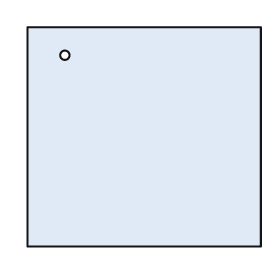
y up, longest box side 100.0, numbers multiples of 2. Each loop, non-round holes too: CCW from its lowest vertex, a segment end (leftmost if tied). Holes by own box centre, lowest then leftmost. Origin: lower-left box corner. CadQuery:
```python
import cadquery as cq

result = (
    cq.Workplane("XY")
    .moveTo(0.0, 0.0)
    .lineTo(100.0, 0.0)
    .lineTo(100.0, 94.0)
    .lineTo(0.0, 94.0)
    .close()
    .moveTo(16.0, 82.0)
    .circle(2.0)
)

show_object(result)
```